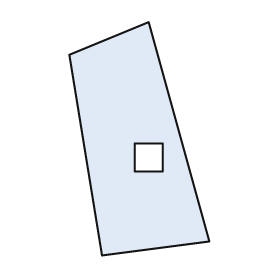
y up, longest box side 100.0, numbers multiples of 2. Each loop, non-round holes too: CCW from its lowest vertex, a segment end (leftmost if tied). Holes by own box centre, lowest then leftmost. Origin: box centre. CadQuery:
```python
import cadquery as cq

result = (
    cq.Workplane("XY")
    .moveTo(-16.0, -50.0)
    .lineTo(30.0, -44.0)
    .lineTo(4.0, 50.0)
    .lineTo(-30.0, 36.0)
    .close()
    .moveTo(-2.0, -14.0)
    .lineTo(10.0, -14.0)
    .lineTo(10.0, -2.0)
    .lineTo(-2.0, -2.0)
    .close()
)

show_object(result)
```